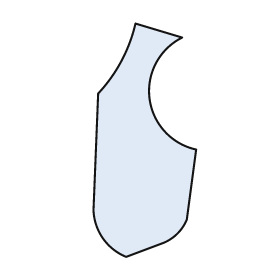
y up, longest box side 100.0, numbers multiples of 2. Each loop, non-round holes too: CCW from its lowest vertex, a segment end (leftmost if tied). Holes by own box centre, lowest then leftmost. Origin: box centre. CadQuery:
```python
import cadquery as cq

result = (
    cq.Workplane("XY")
    .moveTo(-8.0, -50.0)
    .lineTo(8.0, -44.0)
    .threePointArc((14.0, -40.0), (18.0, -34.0))
    .lineTo(22.0, -4.0)
    .threePointArc((2.0, 18.0), (16.0, 44.0))
    .lineTo(-4.0, 50.0)
    .threePointArc((-10.0, 34.0), (-20.0, 20.0))
    .lineTo(-22.0, -30.0)
    .threePointArc((-18.0, -42.0), (-8.0, -50.0))
    .close()
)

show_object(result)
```